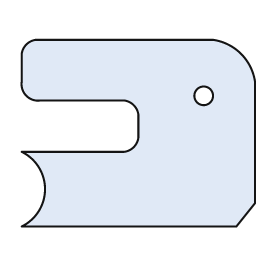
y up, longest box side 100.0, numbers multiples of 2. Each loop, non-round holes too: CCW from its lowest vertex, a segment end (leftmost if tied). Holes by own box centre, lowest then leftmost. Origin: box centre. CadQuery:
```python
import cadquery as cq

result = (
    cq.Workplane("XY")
    .moveTo(-50.0, -40.0)
    .lineTo(42.0, -40.0)
    .lineTo(50.0, -30.0)
    .lineTo(50.0, 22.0)
    .threePointArc((44.0, 34.0), (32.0, 40.0))
    .lineTo(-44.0, 40.0)
    .threePointArc((-48.0, 38.0), (-50.0, 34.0))
    .lineTo(-50.0, 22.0)
    .threePointArc((-48.0, 16.0), (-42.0, 14.0))
    .lineTo(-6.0, 14.0)
    .threePointArc((-2.0, 12.0), (0.0, 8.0))
    .lineTo(0.0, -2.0)
    .threePointArc((-2.0, -6.0), (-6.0, -8.0))
    .lineTo(-50.0, -8.0)
    .threePointArc((-40.0, -24.0), (-50.0, -40.0))
    .close()
    .moveTo(28.0, 16.0)
    .circle(4.0)
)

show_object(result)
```